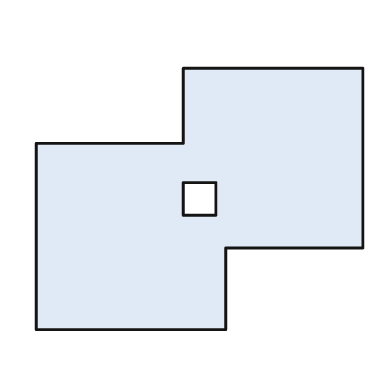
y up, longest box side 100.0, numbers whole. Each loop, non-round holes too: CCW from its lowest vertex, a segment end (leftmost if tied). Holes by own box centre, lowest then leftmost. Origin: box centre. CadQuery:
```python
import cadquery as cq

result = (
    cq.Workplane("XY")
    .moveTo(-50.0, -40.0)
    .lineTo(8.0, -40.0)
    .lineTo(8.0, -15.0)
    .lineTo(50.0, -15.0)
    .lineTo(50.0, 40.0)
    .lineTo(-5.0, 40.0)
    .lineTo(-5.0, 17.0)
    .lineTo(-50.0, 17.0)
    .close()
    .moveTo(-5.0, -5.0)
    .lineTo(5.0, -5.0)
    .lineTo(5.0, 5.0)
    .lineTo(-5.0, 5.0)
    .close()
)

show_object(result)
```